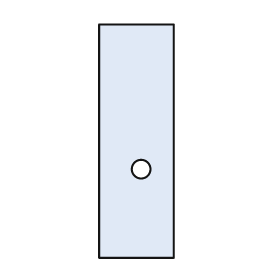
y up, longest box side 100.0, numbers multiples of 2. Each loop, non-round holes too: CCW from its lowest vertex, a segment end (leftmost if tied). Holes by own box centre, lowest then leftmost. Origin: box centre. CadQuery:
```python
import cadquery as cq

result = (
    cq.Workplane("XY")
    .moveTo(-16.0, -50.0)
    .lineTo(16.0, -50.0)
    .lineTo(16.0, 50.0)
    .lineTo(-16.0, 50.0)
    .close()
    .moveTo(2.0, -12.0)
    .circle(4.0)
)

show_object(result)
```